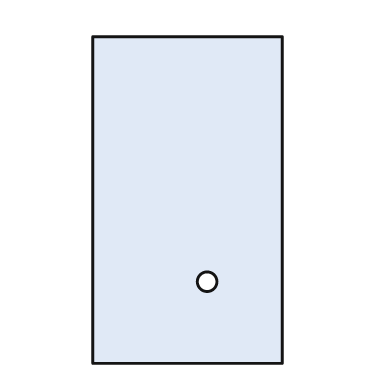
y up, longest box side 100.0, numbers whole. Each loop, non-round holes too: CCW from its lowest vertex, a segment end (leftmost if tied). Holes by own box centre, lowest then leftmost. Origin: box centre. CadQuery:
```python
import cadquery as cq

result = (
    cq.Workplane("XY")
    .moveTo(-29.0, -50.0)
    .lineTo(29.0, -50.0)
    .lineTo(29.0, 50.0)
    .lineTo(-29.0, 50.0)
    .close()
    .moveTo(6.0, -25.0)
    .circle(3.0)
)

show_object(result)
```